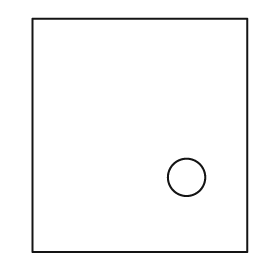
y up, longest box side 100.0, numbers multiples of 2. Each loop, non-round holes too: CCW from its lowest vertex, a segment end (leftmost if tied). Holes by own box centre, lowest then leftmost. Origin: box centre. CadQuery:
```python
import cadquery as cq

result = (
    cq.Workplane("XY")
    .moveTo(-46.0, -50.0)
    .lineTo(46.0, -50.0)
    .lineTo(46.0, 50.0)
    .lineTo(-46.0, 50.0)
    .close()
    .moveTo(20.0, -18.0)
    .circle(8.0)
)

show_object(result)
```